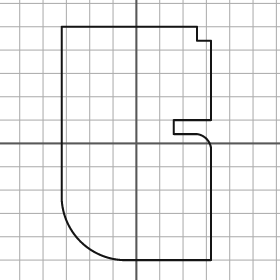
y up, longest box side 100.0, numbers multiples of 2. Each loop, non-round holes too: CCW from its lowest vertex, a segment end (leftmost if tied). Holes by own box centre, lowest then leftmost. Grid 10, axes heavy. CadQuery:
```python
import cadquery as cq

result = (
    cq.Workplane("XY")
    .moveTo(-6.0, -50.0)
    .lineTo(32.0, -50.0)
    .lineTo(32.0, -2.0)
    .threePointArc((30.0, 2.0), (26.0, 4.0))
    .lineTo(16.0, 4.0)
    .lineTo(16.0, 10.0)
    .lineTo(32.0, 10.0)
    .lineTo(32.0, 44.0)
    .lineTo(26.0, 44.0)
    .lineTo(26.0, 50.0)
    .lineTo(-32.0, 50.0)
    .lineTo(-32.0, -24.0)
    .threePointArc((-24.0, -42.0), (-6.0, -50.0))
    .close()
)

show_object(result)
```